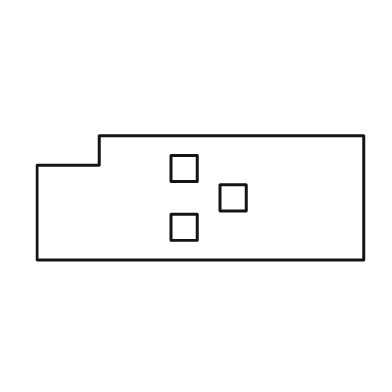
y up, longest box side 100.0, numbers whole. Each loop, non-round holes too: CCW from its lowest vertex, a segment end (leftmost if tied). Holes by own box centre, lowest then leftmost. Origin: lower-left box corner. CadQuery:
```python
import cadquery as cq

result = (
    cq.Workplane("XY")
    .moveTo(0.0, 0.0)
    .lineTo(100.0, 0.0)
    .lineTo(100.0, 38.0)
    .lineTo(19.0, 38.0)
    .lineTo(19.0, 29.0)
    .lineTo(0.0, 29.0)
    .close()
    .moveTo(41.0, 6.0)
    .lineTo(49.0, 6.0)
    .lineTo(49.0, 14.0)
    .lineTo(41.0, 14.0)
    .close()
    .moveTo(56.0, 15.0)
    .lineTo(64.0, 15.0)
    .lineTo(64.0, 23.0)
    .lineTo(56.0, 23.0)
    .close()
    .moveTo(41.0, 24.0)
    .lineTo(49.0, 24.0)
    .lineTo(49.0, 32.0)
    .lineTo(41.0, 32.0)
    .close()
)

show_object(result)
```